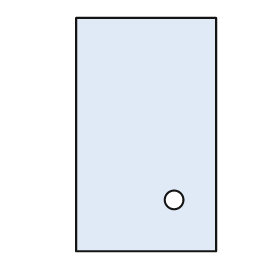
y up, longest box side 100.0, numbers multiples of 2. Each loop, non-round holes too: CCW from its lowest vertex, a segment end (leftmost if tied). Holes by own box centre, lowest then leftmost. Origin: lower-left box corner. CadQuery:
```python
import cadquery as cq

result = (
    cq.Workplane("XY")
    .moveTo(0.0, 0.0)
    .lineTo(60.0, 0.0)
    .lineTo(60.0, 100.0)
    .lineTo(0.0, 100.0)
    .close()
    .moveTo(42.0, 22.0)
    .circle(4.0)
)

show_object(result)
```